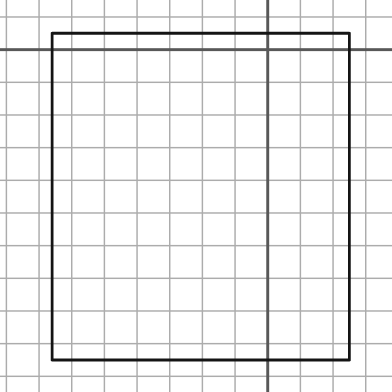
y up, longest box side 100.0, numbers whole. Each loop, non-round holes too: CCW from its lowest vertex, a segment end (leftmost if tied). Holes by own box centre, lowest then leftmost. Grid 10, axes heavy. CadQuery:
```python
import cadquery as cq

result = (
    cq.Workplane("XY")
    .moveTo(-66.0, -95.0)
    .lineTo(25.0, -95.0)
    .lineTo(25.0, 5.0)
    .lineTo(-66.0, 5.0)
    .close()
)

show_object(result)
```